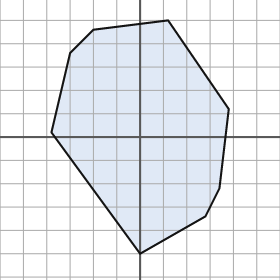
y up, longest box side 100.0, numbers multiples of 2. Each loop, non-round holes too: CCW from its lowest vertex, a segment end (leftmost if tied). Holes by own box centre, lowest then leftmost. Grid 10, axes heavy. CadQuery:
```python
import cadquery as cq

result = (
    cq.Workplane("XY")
    .moveTo(0.0, -50.0)
    .lineTo(28.0, -34.0)
    .lineTo(34.0, -22.0)
    .lineTo(38.0, 12.0)
    .lineTo(12.0, 50.0)
    .lineTo(-20.0, 46.0)
    .lineTo(-30.0, 36.0)
    .lineTo(-38.0, 2.0)
    .close()
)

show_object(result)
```